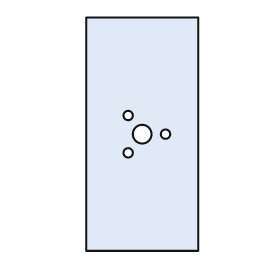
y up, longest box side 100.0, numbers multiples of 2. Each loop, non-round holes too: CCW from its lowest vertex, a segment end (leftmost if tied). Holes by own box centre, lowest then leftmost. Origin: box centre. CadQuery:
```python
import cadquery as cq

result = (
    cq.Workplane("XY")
    .moveTo(-24.0, -50.0)
    .lineTo(24.0, -50.0)
    .lineTo(24.0, 50.0)
    .lineTo(-24.0, 50.0)
    .close()
    .moveTo(-6.0, -8.0)
    .circle(2.0)
    .moveTo(0.0, 0.0)
    .circle(4.0)
    .moveTo(10.0, 0.0)
    .circle(2.0)
    .moveTo(-6.0, 8.0)
    .circle(2.0)
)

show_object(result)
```